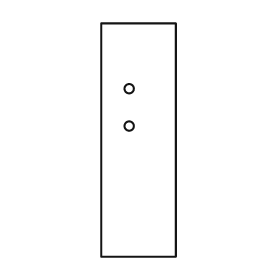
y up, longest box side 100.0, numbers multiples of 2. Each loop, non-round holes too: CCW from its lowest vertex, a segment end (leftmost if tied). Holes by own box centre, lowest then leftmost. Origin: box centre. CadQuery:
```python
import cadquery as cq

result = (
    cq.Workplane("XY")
    .moveTo(-16.0, -50.0)
    .lineTo(16.0, -50.0)
    .lineTo(16.0, 50.0)
    .lineTo(-16.0, 50.0)
    .close()
    .moveTo(-4.0, 6.0)
    .circle(2.0)
    .moveTo(-4.0, 22.0)
    .circle(2.0)
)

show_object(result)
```